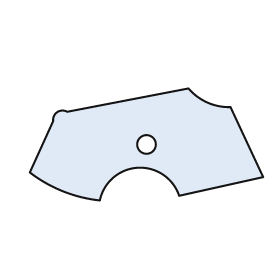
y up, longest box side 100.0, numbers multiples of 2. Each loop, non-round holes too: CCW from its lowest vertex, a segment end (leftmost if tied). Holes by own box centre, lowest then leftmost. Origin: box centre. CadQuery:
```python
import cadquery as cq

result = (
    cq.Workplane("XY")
    .moveTo(-20.0, -24.0)
    .threePointArc((-4.0, -10.0), (14.0, -22.0))
    .lineTo(50.0, -14.0)
    .lineTo(36.0, 16.0)
    .threePointArc((26.0, 18.0), (18.0, 24.0))
    .lineTo(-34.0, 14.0)
    .threePointArc((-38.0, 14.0), (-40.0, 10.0))
    .lineTo(-50.0, -12.0)
    .threePointArc((-36.0, -20.0), (-20.0, -24.0))
    .close()
    .moveTo(0.0, 0.0)
    .circle(4.0)
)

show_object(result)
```